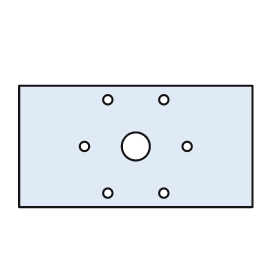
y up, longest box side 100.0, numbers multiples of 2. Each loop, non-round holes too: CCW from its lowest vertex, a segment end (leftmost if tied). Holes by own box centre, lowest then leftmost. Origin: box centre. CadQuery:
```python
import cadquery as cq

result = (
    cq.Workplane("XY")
    .moveTo(-50.0, -26.0)
    .lineTo(50.0, -26.0)
    .lineTo(50.0, 26.0)
    .lineTo(-50.0, 26.0)
    .close()
    .moveTo(-12.0, -20.0)
    .circle(2.0)
    .moveTo(12.0, -20.0)
    .circle(2.0)
    .moveTo(-22.0, 0.0)
    .circle(2.0)
    .moveTo(0.0, 0.0)
    .circle(6.0)
    .moveTo(22.0, 0.0)
    .circle(2.0)
    .moveTo(-12.0, 20.0)
    .circle(2.0)
    .moveTo(12.0, 20.0)
    .circle(2.0)
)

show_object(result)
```